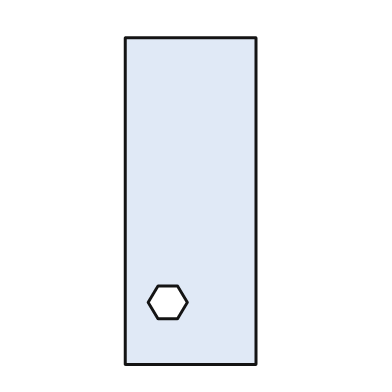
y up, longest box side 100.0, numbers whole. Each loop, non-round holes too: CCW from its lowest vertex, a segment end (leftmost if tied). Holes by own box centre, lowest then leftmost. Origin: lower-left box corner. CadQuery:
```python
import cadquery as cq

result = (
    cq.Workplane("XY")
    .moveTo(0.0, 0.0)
    .lineTo(40.0, 0.0)
    .lineTo(40.0, 100.0)
    .lineTo(0.0, 100.0)
    .close()
    .moveTo(10.0, 14.0)
    .lineTo(16.0, 14.0)
    .lineTo(19.0, 19.0)
    .lineTo(16.0, 24.0)
    .lineTo(10.0, 24.0)
    .lineTo(7.0, 19.0)
    .close()
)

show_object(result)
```